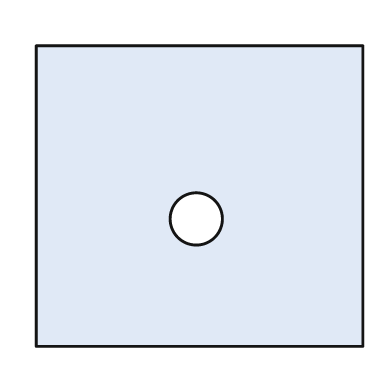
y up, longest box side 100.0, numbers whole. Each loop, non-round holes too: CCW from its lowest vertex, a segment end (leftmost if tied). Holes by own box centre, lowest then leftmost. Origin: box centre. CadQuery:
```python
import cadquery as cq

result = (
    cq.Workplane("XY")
    .moveTo(-50.0, -46.0)
    .lineTo(50.0, -46.0)
    .lineTo(50.0, 46.0)
    .lineTo(-50.0, 46.0)
    .close()
    .moveTo(-1.0, -7.0)
    .circle(8.0)
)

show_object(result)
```